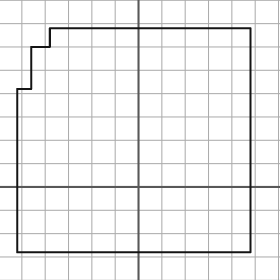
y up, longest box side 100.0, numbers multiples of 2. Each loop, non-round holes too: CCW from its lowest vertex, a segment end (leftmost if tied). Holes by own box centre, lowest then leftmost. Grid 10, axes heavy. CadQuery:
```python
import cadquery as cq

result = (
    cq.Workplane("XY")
    .moveTo(-52.0, -28.0)
    .lineTo(48.0, -28.0)
    .lineTo(48.0, 68.0)
    .lineTo(-38.0, 68.0)
    .lineTo(-38.0, 60.0)
    .lineTo(-46.0, 60.0)
    .lineTo(-46.0, 42.0)
    .lineTo(-52.0, 42.0)
    .close()
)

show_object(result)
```